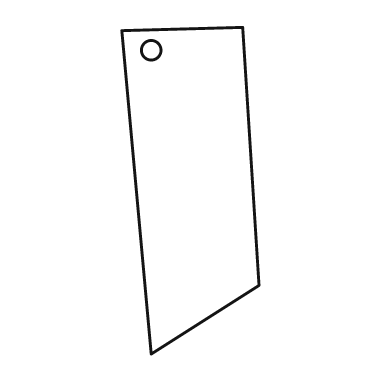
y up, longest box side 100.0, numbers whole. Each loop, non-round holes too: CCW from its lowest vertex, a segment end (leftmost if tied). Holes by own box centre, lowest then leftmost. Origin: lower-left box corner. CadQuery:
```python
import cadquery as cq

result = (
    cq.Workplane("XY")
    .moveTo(9.0, 0.0)
    .lineTo(42.0, 21.0)
    .lineTo(37.0, 100.0)
    .lineTo(0.0, 99.0)
    .close()
    .moveTo(9.0, 93.0)
    .circle(3.0)
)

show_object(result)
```